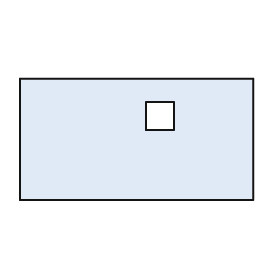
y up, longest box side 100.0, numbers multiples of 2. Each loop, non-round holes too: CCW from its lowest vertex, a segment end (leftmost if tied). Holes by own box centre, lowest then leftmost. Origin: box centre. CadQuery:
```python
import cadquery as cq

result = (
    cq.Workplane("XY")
    .moveTo(-50.0, -26.0)
    .lineTo(50.0, -26.0)
    .lineTo(50.0, 26.0)
    .lineTo(-50.0, 26.0)
    .close()
    .moveTo(4.0, 4.0)
    .lineTo(16.0, 4.0)
    .lineTo(16.0, 16.0)
    .lineTo(4.0, 16.0)
    .close()
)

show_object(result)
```